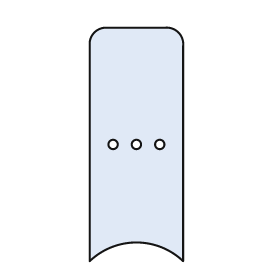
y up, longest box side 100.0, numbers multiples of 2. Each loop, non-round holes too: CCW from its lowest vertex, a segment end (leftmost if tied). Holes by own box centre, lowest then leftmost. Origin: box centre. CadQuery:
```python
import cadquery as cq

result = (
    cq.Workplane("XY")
    .moveTo(-20.0, -50.0)
    .threePointArc((0.0, -42.0), (20.0, -50.0))
    .lineTo(20.0, 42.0)
    .threePointArc((18.0, 48.0), (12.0, 50.0))
    .lineTo(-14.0, 50.0)
    .threePointArc((-18.0, 48.0), (-20.0, 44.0))
    .close()
    .moveTo(-10.0, 0.0)
    .circle(2.0)
    .moveTo(0.0, 0.0)
    .circle(2.0)
    .moveTo(10.0, 0.0)
    .circle(2.0)
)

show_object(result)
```